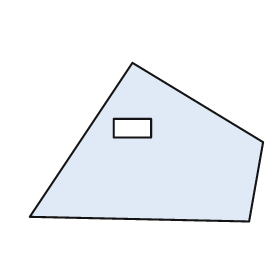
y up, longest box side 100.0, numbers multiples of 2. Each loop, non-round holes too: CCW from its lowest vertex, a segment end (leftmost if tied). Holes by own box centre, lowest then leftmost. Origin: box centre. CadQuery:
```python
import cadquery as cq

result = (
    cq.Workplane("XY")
    .moveTo(44.0, -34.0)
    .lineTo(50.0, 0.0)
    .lineTo(-6.0, 34.0)
    .lineTo(-50.0, -32.0)
    .close()
    .moveTo(-14.0, 2.0)
    .lineTo(2.0, 2.0)
    .lineTo(2.0, 10.0)
    .lineTo(-14.0, 10.0)
    .close()
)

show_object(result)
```